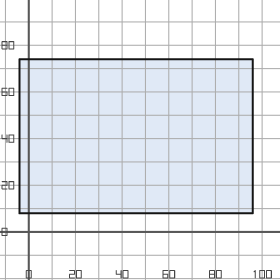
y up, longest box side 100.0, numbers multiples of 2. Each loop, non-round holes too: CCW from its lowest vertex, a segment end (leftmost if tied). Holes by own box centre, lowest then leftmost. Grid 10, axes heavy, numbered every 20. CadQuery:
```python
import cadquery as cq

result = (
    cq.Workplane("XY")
    .moveTo(-4.0, 8.0)
    .lineTo(96.0, 8.0)
    .lineTo(96.0, 74.0)
    .lineTo(-4.0, 74.0)
    .close()
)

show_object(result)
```